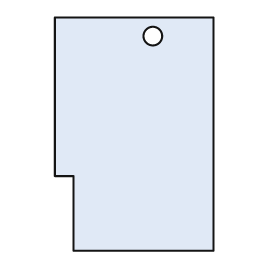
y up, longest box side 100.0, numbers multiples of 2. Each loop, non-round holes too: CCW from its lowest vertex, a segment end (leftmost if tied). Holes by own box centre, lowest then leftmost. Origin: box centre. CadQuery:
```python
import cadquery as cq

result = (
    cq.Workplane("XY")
    .moveTo(-26.0, -50.0)
    .lineTo(34.0, -50.0)
    .lineTo(34.0, 50.0)
    .lineTo(-34.0, 50.0)
    .lineTo(-34.0, -18.0)
    .lineTo(-26.0, -18.0)
    .close()
    .moveTo(8.0, 42.0)
    .circle(4.0)
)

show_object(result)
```